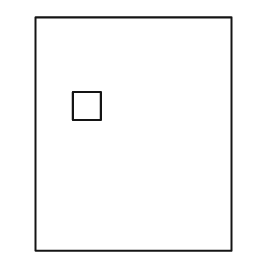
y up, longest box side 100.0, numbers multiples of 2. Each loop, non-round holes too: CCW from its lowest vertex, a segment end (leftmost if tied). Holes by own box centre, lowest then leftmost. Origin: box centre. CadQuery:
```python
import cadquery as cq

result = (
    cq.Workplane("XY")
    .moveTo(-42.0, -50.0)
    .lineTo(42.0, -50.0)
    .lineTo(42.0, 50.0)
    .lineTo(-42.0, 50.0)
    .close()
    .moveTo(-26.0, 6.0)
    .lineTo(-14.0, 6.0)
    .lineTo(-14.0, 18.0)
    .lineTo(-26.0, 18.0)
    .close()
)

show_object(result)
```